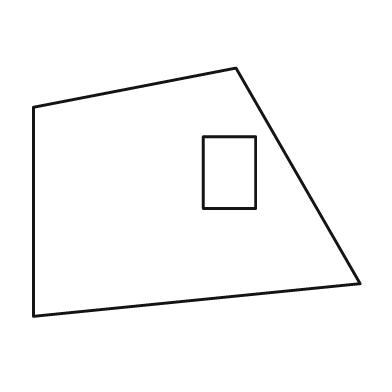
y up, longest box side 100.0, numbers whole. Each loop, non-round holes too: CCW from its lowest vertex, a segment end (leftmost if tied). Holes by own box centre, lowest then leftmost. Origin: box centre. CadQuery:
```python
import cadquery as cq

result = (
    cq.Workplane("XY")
    .moveTo(-50.0, -38.0)
    .lineTo(50.0, -28.0)
    .lineTo(12.0, 38.0)
    .lineTo(-50.0, 26.0)
    .close()
    .moveTo(2.0, -5.0)
    .lineTo(18.0, -5.0)
    .lineTo(18.0, 17.0)
    .lineTo(2.0, 17.0)
    .close()
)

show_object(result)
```